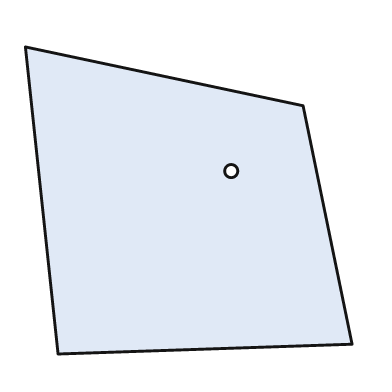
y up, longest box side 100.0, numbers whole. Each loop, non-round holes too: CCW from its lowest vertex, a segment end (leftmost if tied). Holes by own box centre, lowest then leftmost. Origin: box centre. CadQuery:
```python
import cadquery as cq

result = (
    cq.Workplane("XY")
    .moveTo(-40.0, -47.0)
    .lineTo(50.0, -44.0)
    .lineTo(35.0, 29.0)
    .lineTo(-50.0, 47.0)
    .close()
    .moveTo(13.0, 9.0)
    .circle(2.0)
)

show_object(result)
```